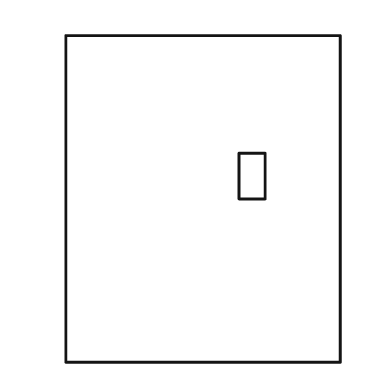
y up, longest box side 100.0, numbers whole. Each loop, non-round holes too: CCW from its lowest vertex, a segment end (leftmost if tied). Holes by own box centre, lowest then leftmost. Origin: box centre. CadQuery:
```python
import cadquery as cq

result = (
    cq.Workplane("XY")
    .moveTo(-42.0, -50.0)
    .lineTo(42.0, -50.0)
    .lineTo(42.0, 50.0)
    .lineTo(-42.0, 50.0)
    .close()
    .moveTo(11.0, 0.0)
    .lineTo(19.0, 0.0)
    .lineTo(19.0, 14.0)
    .lineTo(11.0, 14.0)
    .close()
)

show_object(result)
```